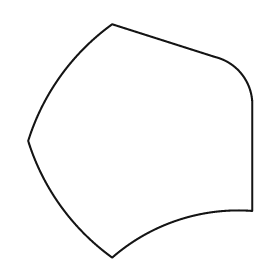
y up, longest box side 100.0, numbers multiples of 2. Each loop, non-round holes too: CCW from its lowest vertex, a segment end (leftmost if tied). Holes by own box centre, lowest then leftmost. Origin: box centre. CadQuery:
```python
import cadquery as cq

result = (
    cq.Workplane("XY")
    .moveTo(-12.0, -50.0)
    .threePointArc((16.0, -34.0), (48.0, -30.0))
    .lineTo(48.0, 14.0)
    .threePointArc((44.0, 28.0), (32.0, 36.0))
    .lineTo(-12.0, 50.0)
    .threePointArc((-34.0, 28.0), (-48.0, 0.0))
    .threePointArc((-34.0, -28.0), (-12.0, -50.0))
    .close()
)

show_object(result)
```